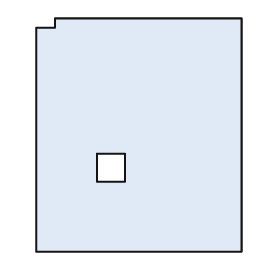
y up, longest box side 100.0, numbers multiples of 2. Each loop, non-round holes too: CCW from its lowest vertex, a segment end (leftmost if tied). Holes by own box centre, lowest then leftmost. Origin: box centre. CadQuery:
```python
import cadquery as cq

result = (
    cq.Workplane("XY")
    .moveTo(-44.0, -50.0)
    .lineTo(44.0, -50.0)
    .lineTo(44.0, 50.0)
    .lineTo(-36.0, 50.0)
    .lineTo(-36.0, 46.0)
    .lineTo(-44.0, 46.0)
    .close()
    .moveTo(-18.0, -20.0)
    .lineTo(-6.0, -20.0)
    .lineTo(-6.0, -8.0)
    .lineTo(-18.0, -8.0)
    .close()
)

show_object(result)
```